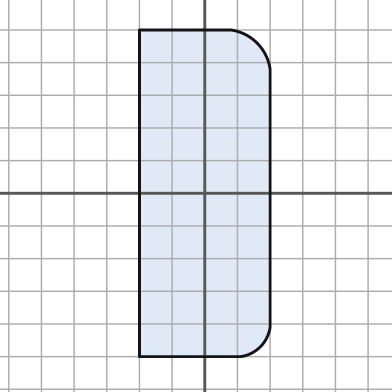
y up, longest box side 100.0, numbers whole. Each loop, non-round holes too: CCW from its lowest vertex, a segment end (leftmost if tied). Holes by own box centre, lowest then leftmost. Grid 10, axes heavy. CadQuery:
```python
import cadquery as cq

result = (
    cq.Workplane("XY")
    .moveTo(-20.0, -50.0)
    .lineTo(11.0, -50.0)
    .threePointArc((17.0, -47.0), (20.0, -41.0))
    .lineTo(20.0, 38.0)
    .threePointArc((16.0, 46.0), (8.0, 50.0))
    .lineTo(-20.0, 50.0)
    .close()
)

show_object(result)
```